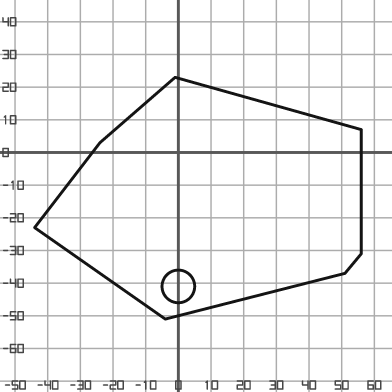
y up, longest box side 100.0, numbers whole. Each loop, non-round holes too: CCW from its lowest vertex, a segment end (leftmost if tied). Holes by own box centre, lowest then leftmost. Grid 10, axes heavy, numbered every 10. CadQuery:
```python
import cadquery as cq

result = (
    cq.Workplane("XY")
    .moveTo(-4.0, -51.0)
    .lineTo(51.0, -37.0)
    .lineTo(56.0, -31.0)
    .lineTo(56.0, 7.0)
    .lineTo(-1.0, 23.0)
    .lineTo(-24.0, 3.0)
    .lineTo(-44.0, -23.0)
    .close()
    .moveTo(0.0, -41.0)
    .circle(5.0)
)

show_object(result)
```